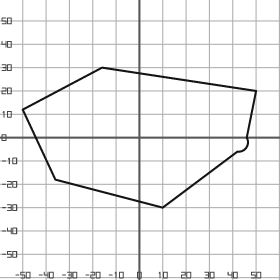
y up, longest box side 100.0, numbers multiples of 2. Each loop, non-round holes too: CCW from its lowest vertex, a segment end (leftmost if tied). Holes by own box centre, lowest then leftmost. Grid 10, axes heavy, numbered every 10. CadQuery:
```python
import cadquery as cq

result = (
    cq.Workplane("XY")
    .moveTo(10.0, -30.0)
    .lineTo(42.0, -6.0)
    .threePointArc((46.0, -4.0), (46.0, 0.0))
    .lineTo(50.0, 20.0)
    .lineTo(-16.0, 30.0)
    .lineTo(-50.0, 12.0)
    .lineTo(-36.0, -18.0)
    .close()
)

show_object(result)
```